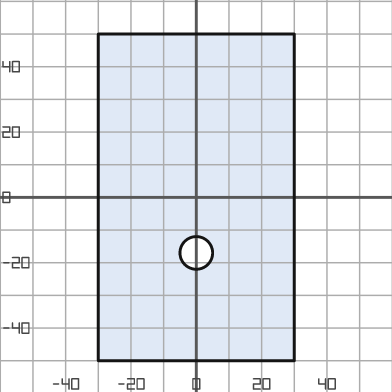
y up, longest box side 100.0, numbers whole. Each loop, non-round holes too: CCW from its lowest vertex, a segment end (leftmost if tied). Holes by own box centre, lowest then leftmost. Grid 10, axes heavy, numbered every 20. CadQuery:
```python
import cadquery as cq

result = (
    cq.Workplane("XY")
    .moveTo(-30.0, -50.0)
    .lineTo(30.0, -50.0)
    .lineTo(30.0, 50.0)
    .lineTo(-30.0, 50.0)
    .close()
    .moveTo(0.0, -17.0)
    .circle(5.0)
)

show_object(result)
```